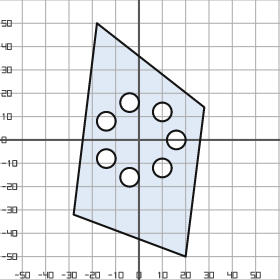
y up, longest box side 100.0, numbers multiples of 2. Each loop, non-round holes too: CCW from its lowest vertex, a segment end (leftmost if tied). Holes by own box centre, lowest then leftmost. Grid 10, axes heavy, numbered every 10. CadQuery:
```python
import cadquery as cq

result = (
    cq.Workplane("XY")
    .moveTo(20.0, -50.0)
    .lineTo(28.0, 14.0)
    .lineTo(-18.0, 50.0)
    .lineTo(-28.0, -32.0)
    .close()
    .moveTo(-4.0, -16.0)
    .circle(4.0)
    .moveTo(10.0, -12.0)
    .circle(4.0)
    .moveTo(-14.0, -8.0)
    .circle(4.0)
    .moveTo(16.0, 0.0)
    .circle(4.0)
    .moveTo(-14.0, 8.0)
    .circle(4.0)
    .moveTo(10.0, 12.0)
    .circle(4.0)
    .moveTo(-4.0, 16.0)
    .circle(4.0)
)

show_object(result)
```